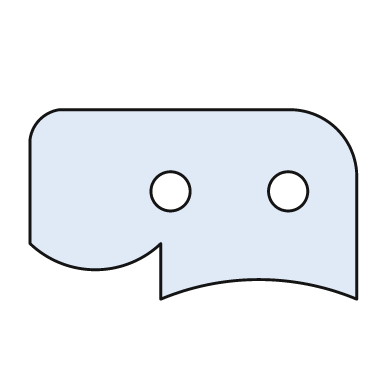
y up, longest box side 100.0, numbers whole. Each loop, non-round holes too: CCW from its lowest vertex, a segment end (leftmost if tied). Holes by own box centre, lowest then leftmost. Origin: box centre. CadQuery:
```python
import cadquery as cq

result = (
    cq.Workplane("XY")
    .moveTo(-10.0, -29.0)
    .threePointArc((20.0, -23.0), (50.0, -29.0))
    .lineTo(50.0, 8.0)
    .threePointArc((44.0, 23.0), (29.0, 29.0))
    .lineTo(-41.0, 29.0)
    .threePointArc((-47.0, 26.0), (-50.0, 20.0))
    .lineTo(-50.0, -12.0)
    .threePointArc((-30.0, -20.0), (-10.0, -12.0))
    .close()
    .moveTo(-7.0, 4.0)
    .circle(6.0)
    .moveTo(29.0, 4.0)
    .circle(6.0)
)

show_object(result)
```